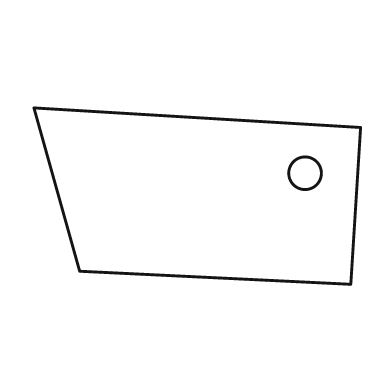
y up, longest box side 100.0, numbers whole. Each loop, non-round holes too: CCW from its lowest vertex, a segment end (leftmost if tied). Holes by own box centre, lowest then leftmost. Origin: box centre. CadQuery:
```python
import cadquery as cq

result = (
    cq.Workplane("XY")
    .moveTo(47.0, -27.0)
    .lineTo(50.0, 21.0)
    .lineTo(-50.0, 27.0)
    .lineTo(-36.0, -23.0)
    .close()
    .moveTo(33.0, 7.0)
    .circle(5.0)
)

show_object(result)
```